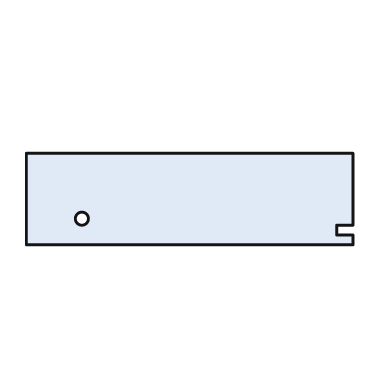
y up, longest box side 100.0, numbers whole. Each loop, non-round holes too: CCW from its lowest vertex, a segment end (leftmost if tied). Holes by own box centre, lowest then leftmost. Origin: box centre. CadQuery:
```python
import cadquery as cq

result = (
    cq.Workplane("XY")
    .moveTo(-50.0, -14.0)
    .lineTo(50.0, -14.0)
    .lineTo(50.0, -11.0)
    .lineTo(45.0, -11.0)
    .lineTo(45.0, -8.0)
    .lineTo(50.0, -8.0)
    .lineTo(50.0, 14.0)
    .lineTo(-50.0, 14.0)
    .close()
    .moveTo(-33.0, -6.0)
    .circle(2.0)
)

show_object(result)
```